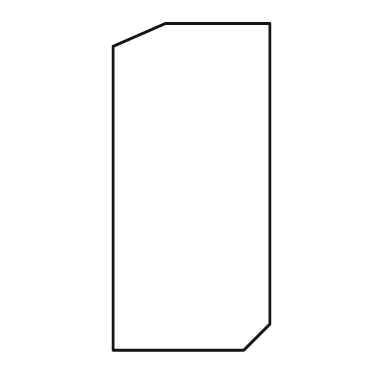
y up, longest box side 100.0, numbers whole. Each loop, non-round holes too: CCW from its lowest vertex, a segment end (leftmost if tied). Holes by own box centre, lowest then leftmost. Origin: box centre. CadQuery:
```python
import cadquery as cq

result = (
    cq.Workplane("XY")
    .moveTo(-24.0, -50.0)
    .lineTo(16.0, -50.0)
    .lineTo(24.0, -42.0)
    .lineTo(24.0, 50.0)
    .lineTo(-8.0, 50.0)
    .lineTo(-24.0, 43.0)
    .close()
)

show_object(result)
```